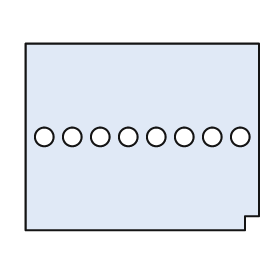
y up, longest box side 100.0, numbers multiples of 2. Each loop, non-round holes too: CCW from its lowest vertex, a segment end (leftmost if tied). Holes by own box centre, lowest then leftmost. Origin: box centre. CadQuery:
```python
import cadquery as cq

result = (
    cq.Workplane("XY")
    .moveTo(-50.0, -40.0)
    .lineTo(44.0, -40.0)
    .lineTo(44.0, -34.0)
    .lineTo(50.0, -34.0)
    .lineTo(50.0, 40.0)
    .lineTo(-50.0, 40.0)
    .close()
    .moveTo(-42.0, 0.0)
    .circle(4.0)
    .moveTo(-30.0, 0.0)
    .circle(4.0)
    .moveTo(-18.0, 0.0)
    .circle(4.0)
    .moveTo(-6.0, 0.0)
    .circle(4.0)
    .moveTo(6.0, 0.0)
    .circle(4.0)
    .moveTo(18.0, 0.0)
    .circle(4.0)
    .moveTo(30.0, 0.0)
    .circle(4.0)
    .moveTo(42.0, 0.0)
    .circle(4.0)
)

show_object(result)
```